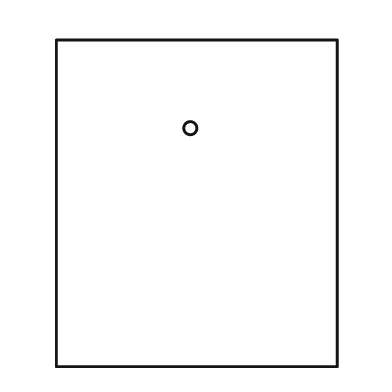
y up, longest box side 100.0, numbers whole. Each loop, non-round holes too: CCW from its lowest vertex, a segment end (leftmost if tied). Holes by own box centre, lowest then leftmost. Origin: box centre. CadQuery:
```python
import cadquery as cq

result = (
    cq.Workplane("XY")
    .moveTo(-43.0, -50.0)
    .lineTo(43.0, -50.0)
    .lineTo(43.0, 50.0)
    .lineTo(-43.0, 50.0)
    .close()
    .moveTo(-2.0, 23.0)
    .circle(2.0)
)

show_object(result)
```